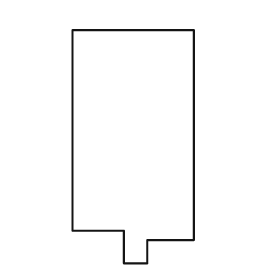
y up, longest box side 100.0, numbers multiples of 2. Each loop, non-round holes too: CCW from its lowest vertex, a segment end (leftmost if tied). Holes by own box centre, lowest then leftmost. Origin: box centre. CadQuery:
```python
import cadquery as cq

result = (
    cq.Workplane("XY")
    .moveTo(-4.0, -50.0)
    .lineTo(6.0, -50.0)
    .lineTo(6.0, -40.0)
    .lineTo(26.0, -40.0)
    .lineTo(26.0, 50.0)
    .lineTo(-26.0, 50.0)
    .lineTo(-26.0, -36.0)
    .lineTo(-4.0, -36.0)
    .close()
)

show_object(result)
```